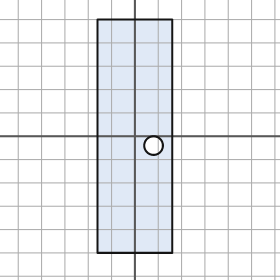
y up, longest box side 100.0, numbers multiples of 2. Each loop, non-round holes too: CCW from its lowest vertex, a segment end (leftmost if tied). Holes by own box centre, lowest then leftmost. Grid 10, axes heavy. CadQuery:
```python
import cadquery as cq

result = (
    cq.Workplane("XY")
    .moveTo(-16.0, -50.0)
    .lineTo(16.0, -50.0)
    .lineTo(16.0, 50.0)
    .lineTo(-16.0, 50.0)
    .close()
    .moveTo(8.0, -4.0)
    .circle(4.0)
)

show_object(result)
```